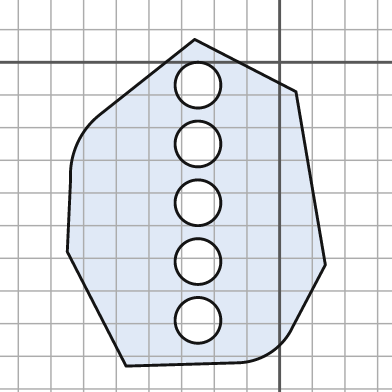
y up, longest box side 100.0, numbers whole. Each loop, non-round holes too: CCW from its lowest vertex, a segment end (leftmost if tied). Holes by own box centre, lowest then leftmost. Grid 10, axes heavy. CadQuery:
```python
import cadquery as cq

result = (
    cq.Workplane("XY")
    .moveTo(-47.0, -93.0)
    .lineTo(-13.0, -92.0)
    .threePointArc((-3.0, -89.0), (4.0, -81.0))
    .lineTo(14.0, -62.0)
    .lineTo(5.0, -9.0)
    .lineTo(-26.0, 7.0)
    .lineTo(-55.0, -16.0)
    .threePointArc((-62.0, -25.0), (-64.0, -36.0))
    .lineTo(-65.0, -58.0)
    .close()
    .moveTo(-25.0, -79.0)
    .circle(7.0)
    .moveTo(-25.0, -61.0)
    .circle(7.0)
    .moveTo(-25.0, -43.0)
    .circle(7.0)
    .moveTo(-25.0, -25.0)
    .circle(7.0)
    .moveTo(-25.0, -7.0)
    .circle(7.0)
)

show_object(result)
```